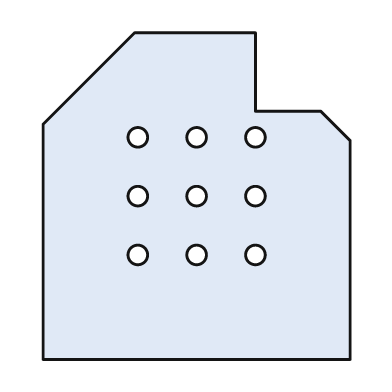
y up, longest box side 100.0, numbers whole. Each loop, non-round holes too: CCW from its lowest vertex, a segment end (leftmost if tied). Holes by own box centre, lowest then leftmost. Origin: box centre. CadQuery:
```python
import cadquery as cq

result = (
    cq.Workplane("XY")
    .moveTo(-47.0, -50.0)
    .lineTo(47.0, -50.0)
    .lineTo(47.0, 17.0)
    .lineTo(38.0, 26.0)
    .lineTo(18.0, 26.0)
    .lineTo(18.0, 50.0)
    .lineTo(-19.0, 50.0)
    .lineTo(-47.0, 22.0)
    .close()
    .moveTo(-18.0, -18.0)
    .circle(3.0)
    .moveTo(0.0, -18.0)
    .circle(3.0)
    .moveTo(18.0, -18.0)
    .circle(3.0)
    .moveTo(-18.0, 0.0)
    .circle(3.0)
    .moveTo(0.0, 0.0)
    .circle(3.0)
    .moveTo(18.0, 0.0)
    .circle(3.0)
    .moveTo(-18.0, 18.0)
    .circle(3.0)
    .moveTo(0.0, 18.0)
    .circle(3.0)
    .moveTo(18.0, 18.0)
    .circle(3.0)
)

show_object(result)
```